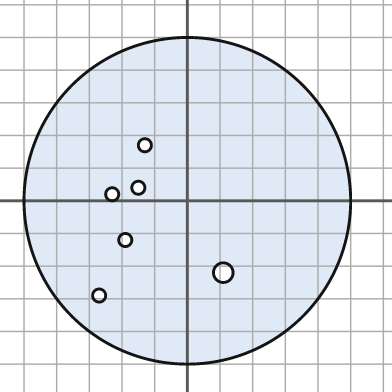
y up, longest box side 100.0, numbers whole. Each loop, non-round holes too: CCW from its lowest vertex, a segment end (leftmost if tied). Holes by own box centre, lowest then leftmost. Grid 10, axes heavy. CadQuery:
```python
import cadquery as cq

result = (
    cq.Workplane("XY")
    .moveTo(0.0, 0.0)
    .circle(50.0)
    .moveTo(-27.0, -29.0)
    .circle(2.0)
    .moveTo(11.0, -22.0)
    .circle(3.0)
    .moveTo(-19.0, -12.0)
    .circle(2.0)
    .moveTo(-23.0, 2.0)
    .circle(2.0)
    .moveTo(-15.0, 4.0)
    .circle(2.0)
    .moveTo(-13.0, 17.0)
    .circle(2.0)
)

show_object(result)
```